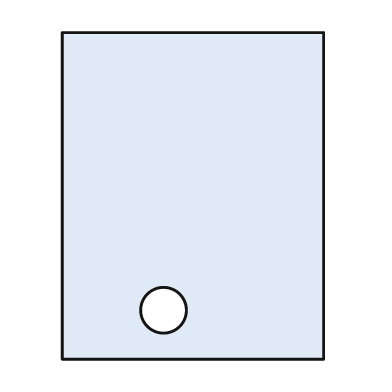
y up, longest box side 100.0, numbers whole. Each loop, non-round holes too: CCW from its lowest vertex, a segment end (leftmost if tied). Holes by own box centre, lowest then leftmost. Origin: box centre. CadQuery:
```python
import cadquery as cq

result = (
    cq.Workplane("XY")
    .moveTo(-40.0, -50.0)
    .lineTo(40.0, -50.0)
    .lineTo(40.0, 50.0)
    .lineTo(-40.0, 50.0)
    .close()
    .moveTo(-9.0, -35.0)
    .circle(7.0)
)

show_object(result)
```